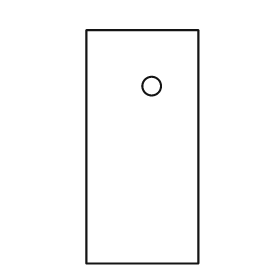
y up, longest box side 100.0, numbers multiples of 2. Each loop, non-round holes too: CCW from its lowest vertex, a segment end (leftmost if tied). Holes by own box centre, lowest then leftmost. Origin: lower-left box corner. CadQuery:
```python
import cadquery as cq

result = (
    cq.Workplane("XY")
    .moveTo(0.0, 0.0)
    .lineTo(48.0, 0.0)
    .lineTo(48.0, 100.0)
    .lineTo(0.0, 100.0)
    .close()
    .moveTo(28.0, 76.0)
    .circle(4.0)
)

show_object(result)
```